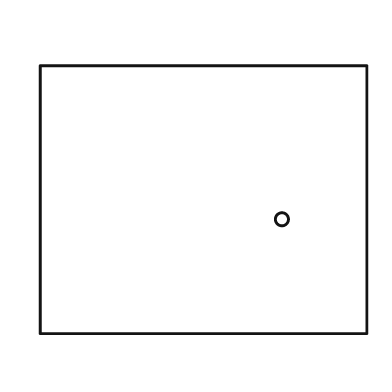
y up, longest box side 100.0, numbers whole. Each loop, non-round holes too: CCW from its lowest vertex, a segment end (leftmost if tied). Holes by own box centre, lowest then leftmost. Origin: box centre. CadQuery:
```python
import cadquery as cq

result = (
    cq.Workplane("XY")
    .moveTo(-50.0, -41.0)
    .lineTo(50.0, -41.0)
    .lineTo(50.0, 41.0)
    .lineTo(-50.0, 41.0)
    .close()
    .moveTo(24.0, -6.0)
    .circle(2.0)
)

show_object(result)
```